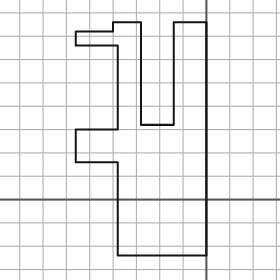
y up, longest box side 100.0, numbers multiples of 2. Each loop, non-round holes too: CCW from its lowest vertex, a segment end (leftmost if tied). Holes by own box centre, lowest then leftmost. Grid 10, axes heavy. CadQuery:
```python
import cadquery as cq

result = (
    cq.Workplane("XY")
    .moveTo(-38.0, -24.0)
    .lineTo(0.0, -24.0)
    .lineTo(0.0, 76.0)
    .lineTo(-14.0, 76.0)
    .lineTo(-14.0, 32.0)
    .lineTo(-28.0, 32.0)
    .lineTo(-28.0, 76.0)
    .lineTo(-40.0, 76.0)
    .lineTo(-40.0, 72.0)
    .lineTo(-56.0, 72.0)
    .lineTo(-56.0, 66.0)
    .lineTo(-38.0, 66.0)
    .lineTo(-38.0, 30.0)
    .lineTo(-56.0, 30.0)
    .lineTo(-56.0, 16.0)
    .lineTo(-38.0, 16.0)
    .close()
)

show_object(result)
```